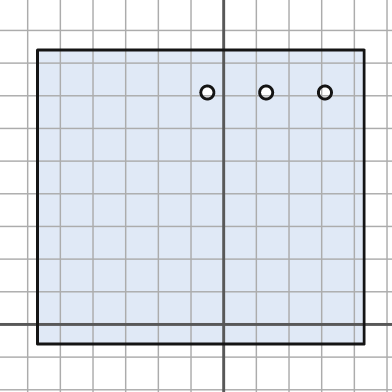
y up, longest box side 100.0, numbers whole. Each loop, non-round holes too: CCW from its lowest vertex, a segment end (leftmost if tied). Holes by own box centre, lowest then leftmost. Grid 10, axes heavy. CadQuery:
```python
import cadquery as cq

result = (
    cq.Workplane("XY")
    .moveTo(-57.0, -6.0)
    .lineTo(43.0, -6.0)
    .lineTo(43.0, 84.0)
    .lineTo(-57.0, 84.0)
    .close()
    .moveTo(-5.0, 71.0)
    .circle(2.0)
    .moveTo(13.0, 71.0)
    .circle(2.0)
    .moveTo(31.0, 71.0)
    .circle(2.0)
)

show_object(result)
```